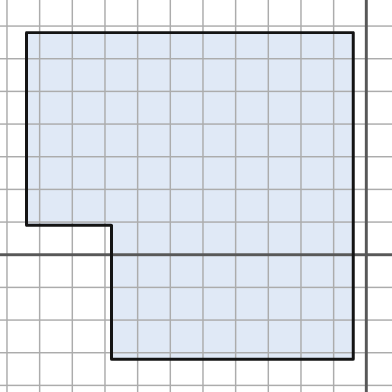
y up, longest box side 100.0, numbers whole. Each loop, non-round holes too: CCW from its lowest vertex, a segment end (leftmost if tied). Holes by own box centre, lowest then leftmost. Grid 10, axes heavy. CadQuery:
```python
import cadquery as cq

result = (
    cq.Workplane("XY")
    .moveTo(-78.0, -32.0)
    .lineTo(-4.0, -32.0)
    .lineTo(-4.0, 68.0)
    .lineTo(-104.0, 68.0)
    .lineTo(-104.0, 9.0)
    .lineTo(-78.0, 9.0)
    .close()
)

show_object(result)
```